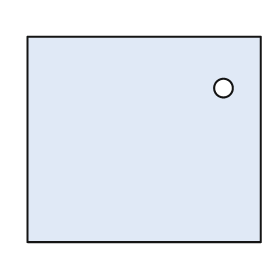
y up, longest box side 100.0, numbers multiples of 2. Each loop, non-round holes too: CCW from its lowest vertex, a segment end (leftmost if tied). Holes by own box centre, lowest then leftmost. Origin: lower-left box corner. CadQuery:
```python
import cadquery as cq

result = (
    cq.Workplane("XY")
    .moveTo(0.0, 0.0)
    .lineTo(100.0, 0.0)
    .lineTo(100.0, 88.0)
    .lineTo(0.0, 88.0)
    .close()
    .moveTo(84.0, 66.0)
    .circle(4.0)
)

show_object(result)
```